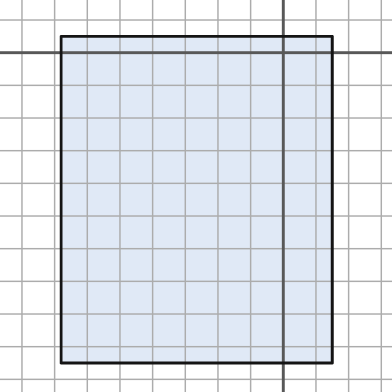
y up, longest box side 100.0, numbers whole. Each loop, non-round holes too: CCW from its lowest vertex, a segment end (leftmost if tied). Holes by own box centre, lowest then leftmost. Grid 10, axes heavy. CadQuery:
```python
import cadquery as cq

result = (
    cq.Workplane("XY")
    .moveTo(-68.0, -95.0)
    .lineTo(15.0, -95.0)
    .lineTo(15.0, 5.0)
    .lineTo(-68.0, 5.0)
    .close()
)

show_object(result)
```